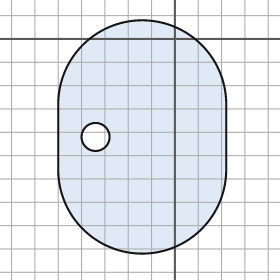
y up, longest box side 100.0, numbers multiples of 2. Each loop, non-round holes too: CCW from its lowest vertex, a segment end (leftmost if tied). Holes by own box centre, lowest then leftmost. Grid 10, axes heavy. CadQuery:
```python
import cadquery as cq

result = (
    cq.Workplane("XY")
    .moveTo(-50.0, -56.0)
    .threePointArc((-14.0, -92.0), (22.0, -56.0))
    .lineTo(22.0, -28.0)
    .threePointArc((-14.0, 8.0), (-50.0, -28.0))
    .close()
    .moveTo(-34.0, -42.0)
    .circle(6.0)
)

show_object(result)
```